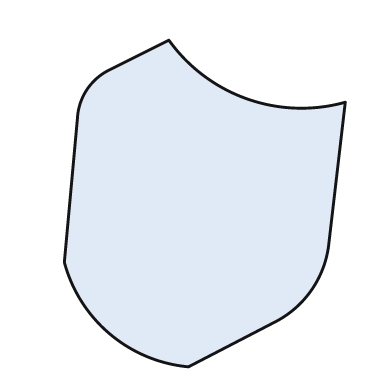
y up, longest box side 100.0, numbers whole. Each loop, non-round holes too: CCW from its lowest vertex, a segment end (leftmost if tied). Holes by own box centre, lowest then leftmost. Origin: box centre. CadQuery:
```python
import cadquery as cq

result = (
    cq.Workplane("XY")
    .moveTo(-5.0, -50.0)
    .lineTo(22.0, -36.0)
    .threePointArc((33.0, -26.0), (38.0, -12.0))
    .lineTo(43.0, 31.0)
    .threePointArc((13.0, 32.0), (-11.0, 50.0))
    .lineTo(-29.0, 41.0)
    .threePointArc((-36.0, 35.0), (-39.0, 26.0))
    .lineTo(-43.0, -18.0)
    .threePointArc((-29.0, -40.0), (-5.0, -50.0))
    .close()
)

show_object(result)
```